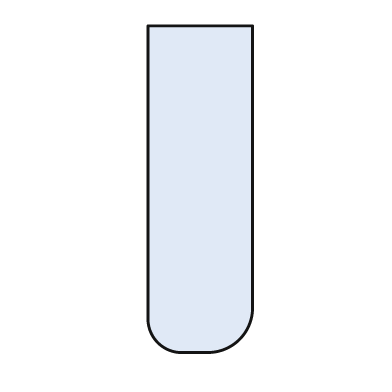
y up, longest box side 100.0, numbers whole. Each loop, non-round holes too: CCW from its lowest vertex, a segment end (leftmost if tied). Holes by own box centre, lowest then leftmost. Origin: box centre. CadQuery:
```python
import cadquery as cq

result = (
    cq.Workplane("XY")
    .moveTo(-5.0, -50.0)
    .lineTo(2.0, -50.0)
    .threePointArc((12.0, -46.0), (16.0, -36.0))
    .lineTo(16.0, 50.0)
    .lineTo(-16.0, 50.0)
    .lineTo(-16.0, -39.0)
    .threePointArc((-13.0, -47.0), (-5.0, -50.0))
    .close()
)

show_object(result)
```